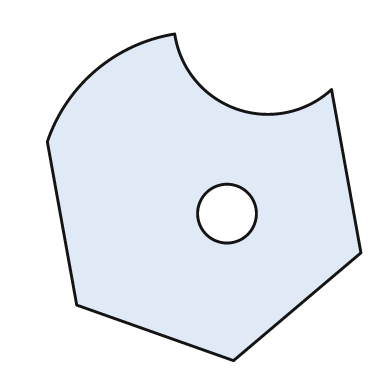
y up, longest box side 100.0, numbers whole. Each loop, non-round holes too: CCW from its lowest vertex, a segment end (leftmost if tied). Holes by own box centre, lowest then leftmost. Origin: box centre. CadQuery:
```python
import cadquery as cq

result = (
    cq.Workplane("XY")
    .moveTo(9.0, -50.0)
    .lineTo(48.0, -17.0)
    .lineTo(39.0, 33.0)
    .threePointArc((10.0, 27.0), (-9.0, 50.0))
    .threePointArc((-33.0, 39.0), (-48.0, 17.0))
    .lineTo(-39.0, -33.0)
    .close()
    .moveTo(7.0, -5.0)
    .circle(9.0)
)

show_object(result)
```